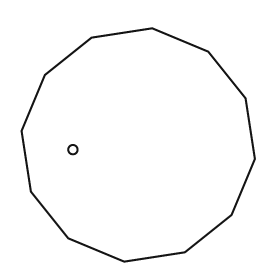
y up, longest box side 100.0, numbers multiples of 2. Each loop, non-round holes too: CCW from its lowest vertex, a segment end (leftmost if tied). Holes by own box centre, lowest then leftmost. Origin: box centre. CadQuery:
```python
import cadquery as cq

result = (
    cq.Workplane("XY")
    .moveTo(-6.0, -50.0)
    .lineTo(20.0, -46.0)
    .lineTo(40.0, -30.0)
    .lineTo(50.0, -6.0)
    .lineTo(46.0, 20.0)
    .lineTo(30.0, 40.0)
    .lineTo(6.0, 50.0)
    .lineTo(-20.0, 46.0)
    .lineTo(-40.0, 30.0)
    .lineTo(-50.0, 6.0)
    .lineTo(-46.0, -20.0)
    .lineTo(-30.0, -40.0)
    .close()
    .moveTo(-28.0, -2.0)
    .circle(2.0)
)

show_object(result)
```